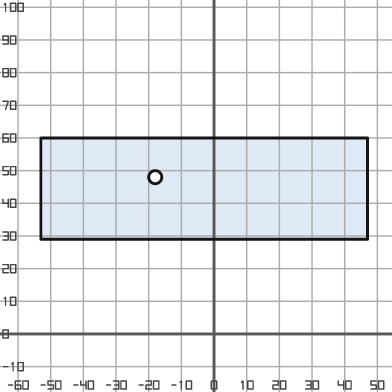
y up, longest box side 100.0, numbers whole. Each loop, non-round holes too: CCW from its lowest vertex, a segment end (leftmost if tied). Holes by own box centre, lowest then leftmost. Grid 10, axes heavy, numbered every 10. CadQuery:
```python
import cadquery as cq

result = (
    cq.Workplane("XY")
    .moveTo(-53.0, 29.0)
    .lineTo(47.0, 29.0)
    .lineTo(47.0, 60.0)
    .lineTo(-53.0, 60.0)
    .close()
    .moveTo(-18.0, 48.0)
    .circle(2.0)
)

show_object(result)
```